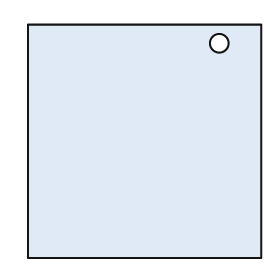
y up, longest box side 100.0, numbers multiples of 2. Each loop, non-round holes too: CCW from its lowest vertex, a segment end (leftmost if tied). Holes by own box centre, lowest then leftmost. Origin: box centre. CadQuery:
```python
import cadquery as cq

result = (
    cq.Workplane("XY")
    .moveTo(-50.0, -50.0)
    .lineTo(50.0, -50.0)
    .lineTo(50.0, 50.0)
    .lineTo(-50.0, 50.0)
    .close()
    .moveTo(32.0, 42.0)
    .circle(4.0)
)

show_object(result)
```